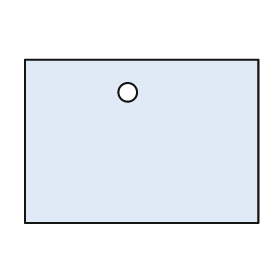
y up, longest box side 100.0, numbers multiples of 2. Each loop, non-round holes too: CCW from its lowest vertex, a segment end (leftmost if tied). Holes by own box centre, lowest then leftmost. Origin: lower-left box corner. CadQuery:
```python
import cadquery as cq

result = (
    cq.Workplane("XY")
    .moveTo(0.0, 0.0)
    .lineTo(100.0, 0.0)
    .lineTo(100.0, 70.0)
    .lineTo(0.0, 70.0)
    .close()
    .moveTo(44.0, 56.0)
    .circle(4.0)
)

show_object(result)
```